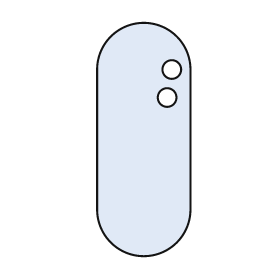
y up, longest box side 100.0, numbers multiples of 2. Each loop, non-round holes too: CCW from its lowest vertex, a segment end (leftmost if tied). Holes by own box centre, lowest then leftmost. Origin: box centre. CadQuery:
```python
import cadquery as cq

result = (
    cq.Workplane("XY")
    .moveTo(-20.0, -30.0)
    .threePointArc((0.0, -50.0), (20.0, -30.0))
    .lineTo(20.0, 30.0)
    .threePointArc((0.0, 50.0), (-20.0, 30.0))
    .close()
    .moveTo(10.0, 18.0)
    .circle(4.0)
    .moveTo(12.0, 30.0)
    .circle(4.0)
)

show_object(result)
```